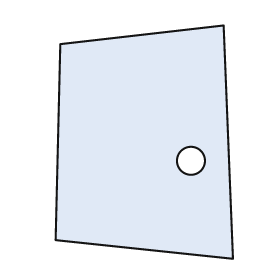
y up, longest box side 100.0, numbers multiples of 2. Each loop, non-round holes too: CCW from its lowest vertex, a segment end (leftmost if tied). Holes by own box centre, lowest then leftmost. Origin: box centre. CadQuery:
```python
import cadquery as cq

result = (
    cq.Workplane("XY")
    .moveTo(38.0, -50.0)
    .lineTo(34.0, 50.0)
    .lineTo(-36.0, 42.0)
    .lineTo(-38.0, -42.0)
    .close()
    .moveTo(20.0, -8.0)
    .circle(6.0)
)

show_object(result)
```